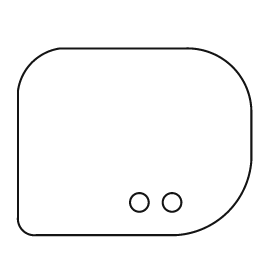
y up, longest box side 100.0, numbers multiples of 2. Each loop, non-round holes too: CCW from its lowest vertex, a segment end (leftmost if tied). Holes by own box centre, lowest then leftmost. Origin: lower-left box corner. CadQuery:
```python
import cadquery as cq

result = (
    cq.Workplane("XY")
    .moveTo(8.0, 0.0)
    .lineTo(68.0, 0.0)
    .threePointArc((90.0, 10.0), (100.0, 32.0))
    .lineTo(100.0, 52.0)
    .threePointArc((92.0, 72.0), (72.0, 80.0))
    .lineTo(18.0, 80.0)
    .threePointArc((6.0, 74.0), (0.0, 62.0))
    .lineTo(0.0, 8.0)
    .threePointArc((2.0, 2.0), (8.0, 0.0))
    .close()
    .moveTo(52.0, 14.0)
    .circle(4.0)
    .moveTo(66.0, 14.0)
    .circle(4.0)
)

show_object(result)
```